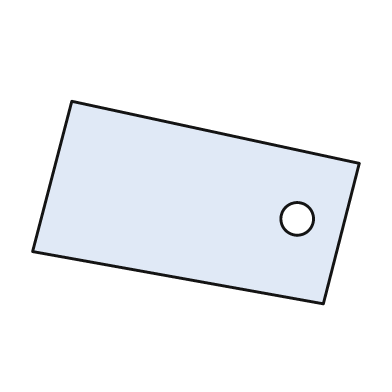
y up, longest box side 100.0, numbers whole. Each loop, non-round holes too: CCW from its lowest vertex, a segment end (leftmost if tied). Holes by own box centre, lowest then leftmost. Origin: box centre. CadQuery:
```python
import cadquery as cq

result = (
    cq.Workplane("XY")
    .moveTo(39.0, -31.0)
    .lineTo(50.0, 12.0)
    .lineTo(-38.0, 31.0)
    .lineTo(-50.0, -15.0)
    .close()
    .moveTo(31.0, -5.0)
    .circle(5.0)
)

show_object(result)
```